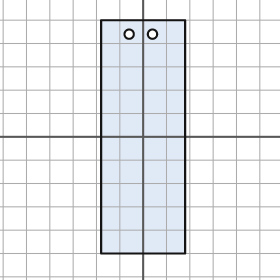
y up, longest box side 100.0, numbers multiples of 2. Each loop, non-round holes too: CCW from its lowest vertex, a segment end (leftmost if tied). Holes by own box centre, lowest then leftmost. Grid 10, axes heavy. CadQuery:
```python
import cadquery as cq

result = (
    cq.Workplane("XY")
    .moveTo(-18.0, -50.0)
    .lineTo(18.0, -50.0)
    .lineTo(18.0, 50.0)
    .lineTo(-18.0, 50.0)
    .close()
    .moveTo(-6.0, 44.0)
    .circle(2.0)
    .moveTo(4.0, 44.0)
    .circle(2.0)
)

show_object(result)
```